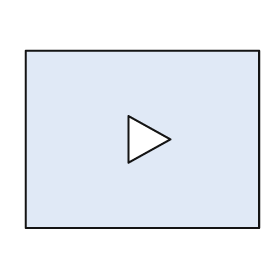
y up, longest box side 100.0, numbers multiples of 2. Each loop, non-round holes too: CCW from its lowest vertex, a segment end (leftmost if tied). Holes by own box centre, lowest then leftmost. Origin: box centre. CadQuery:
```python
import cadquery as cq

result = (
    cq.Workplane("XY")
    .moveTo(-50.0, -38.0)
    .lineTo(50.0, -38.0)
    .lineTo(50.0, 38.0)
    .lineTo(-50.0, 38.0)
    .close()
    .moveTo(-6.0, -10.0)
    .lineTo(12.0, 0.0)
    .lineTo(-6.0, 10.0)
    .close()
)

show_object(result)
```